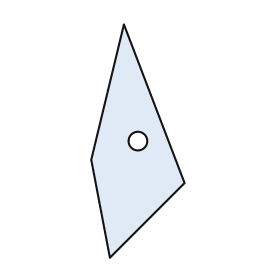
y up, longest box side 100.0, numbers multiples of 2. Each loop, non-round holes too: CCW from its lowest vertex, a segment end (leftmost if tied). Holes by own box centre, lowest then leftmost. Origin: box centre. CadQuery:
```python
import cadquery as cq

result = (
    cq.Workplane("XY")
    .moveTo(-12.0, -50.0)
    .lineTo(20.0, -18.0)
    .lineTo(-6.0, 50.0)
    .lineTo(-20.0, -8.0)
    .close()
    .moveTo(0.0, 0.0)
    .circle(4.0)
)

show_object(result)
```